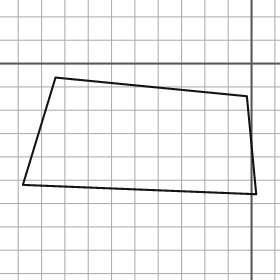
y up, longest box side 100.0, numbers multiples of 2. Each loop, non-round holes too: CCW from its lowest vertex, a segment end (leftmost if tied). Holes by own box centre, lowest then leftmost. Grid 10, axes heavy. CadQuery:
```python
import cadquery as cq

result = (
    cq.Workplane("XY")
    .moveTo(2.0, -56.0)
    .lineTo(-2.0, -14.0)
    .lineTo(-84.0, -6.0)
    .lineTo(-98.0, -52.0)
    .close()
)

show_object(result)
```